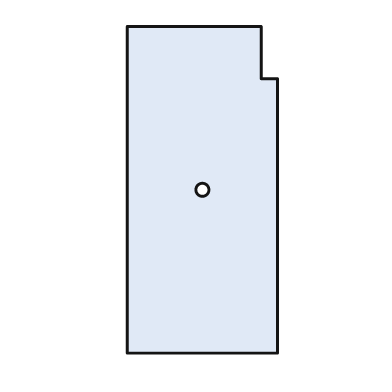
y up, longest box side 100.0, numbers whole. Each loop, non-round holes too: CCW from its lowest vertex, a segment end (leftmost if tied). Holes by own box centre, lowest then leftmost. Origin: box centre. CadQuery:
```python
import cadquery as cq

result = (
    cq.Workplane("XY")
    .moveTo(-23.0, -50.0)
    .lineTo(23.0, -50.0)
    .lineTo(23.0, 34.0)
    .lineTo(18.0, 34.0)
    .lineTo(18.0, 50.0)
    .lineTo(-23.0, 50.0)
    .close()
    .moveTo(0.0, 0.0)
    .circle(2.0)
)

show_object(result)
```